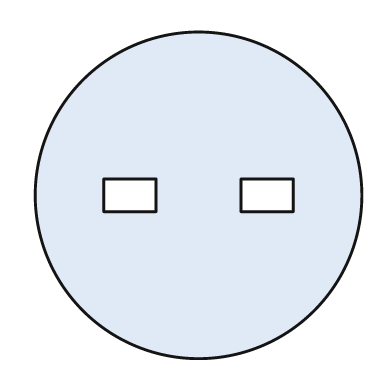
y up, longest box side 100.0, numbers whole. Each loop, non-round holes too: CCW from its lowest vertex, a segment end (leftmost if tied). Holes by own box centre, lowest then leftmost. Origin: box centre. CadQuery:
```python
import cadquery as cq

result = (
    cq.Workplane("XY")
    .moveTo(0.0, 0.0)
    .circle(50.0)
    .moveTo(-29.0, -5.0)
    .lineTo(-13.0, -5.0)
    .lineTo(-13.0, 5.0)
    .lineTo(-29.0, 5.0)
    .close()
    .moveTo(13.0, -5.0)
    .lineTo(29.0, -5.0)
    .lineTo(29.0, 5.0)
    .lineTo(13.0, 5.0)
    .close()
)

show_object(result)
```